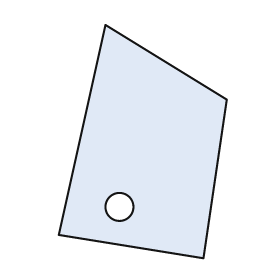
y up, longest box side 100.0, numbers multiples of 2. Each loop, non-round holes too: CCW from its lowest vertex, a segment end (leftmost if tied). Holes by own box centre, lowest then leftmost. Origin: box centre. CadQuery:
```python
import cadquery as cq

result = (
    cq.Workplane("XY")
    .moveTo(26.0, -50.0)
    .lineTo(36.0, 18.0)
    .lineTo(-16.0, 50.0)
    .lineTo(-36.0, -40.0)
    .close()
    .moveTo(-10.0, -28.0)
    .circle(6.0)
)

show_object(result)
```